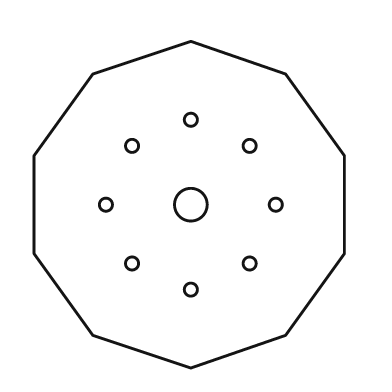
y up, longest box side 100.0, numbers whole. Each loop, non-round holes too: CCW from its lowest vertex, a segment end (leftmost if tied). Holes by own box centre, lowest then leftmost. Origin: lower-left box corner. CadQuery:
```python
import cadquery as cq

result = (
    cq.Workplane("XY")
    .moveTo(48.0, 0.0)
    .lineTo(77.0, 10.0)
    .lineTo(95.0, 35.0)
    .lineTo(95.0, 65.0)
    .lineTo(77.0, 90.0)
    .lineTo(48.0, 100.0)
    .lineTo(18.0, 90.0)
    .lineTo(0.0, 65.0)
    .lineTo(0.0, 35.0)
    .lineTo(18.0, 10.0)
    .close()
    .moveTo(48.0, 24.0)
    .circle(2.0)
    .moveTo(30.0, 32.0)
    .circle(2.0)
    .moveTo(66.0, 32.0)
    .circle(2.0)
    .moveTo(22.0, 50.0)
    .circle(2.0)
    .moveTo(48.0, 50.0)
    .circle(5.0)
    .moveTo(74.0, 50.0)
    .circle(2.0)
    .moveTo(30.0, 68.0)
    .circle(2.0)
    .moveTo(66.0, 68.0)
    .circle(2.0)
    .moveTo(48.0, 76.0)
    .circle(2.0)
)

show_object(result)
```